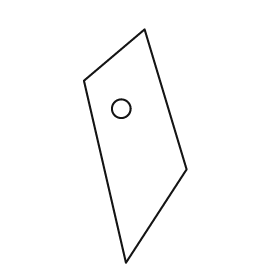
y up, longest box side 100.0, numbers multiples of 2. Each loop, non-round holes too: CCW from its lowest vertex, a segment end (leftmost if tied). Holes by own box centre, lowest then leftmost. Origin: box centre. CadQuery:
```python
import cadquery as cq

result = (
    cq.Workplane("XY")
    .moveTo(-4.0, -50.0)
    .lineTo(22.0, -10.0)
    .lineTo(4.0, 50.0)
    .lineTo(-22.0, 28.0)
    .close()
    .moveTo(-6.0, 16.0)
    .circle(4.0)
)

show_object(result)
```